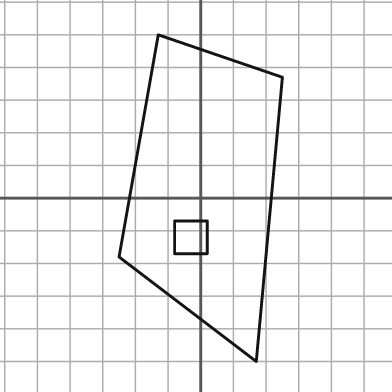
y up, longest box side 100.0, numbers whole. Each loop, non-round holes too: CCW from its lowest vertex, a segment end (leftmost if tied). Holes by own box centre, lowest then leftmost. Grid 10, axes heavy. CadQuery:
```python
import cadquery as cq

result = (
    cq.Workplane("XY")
    .moveTo(17.0, -50.0)
    .lineTo(25.0, 37.0)
    .lineTo(-13.0, 50.0)
    .lineTo(-25.0, -18.0)
    .close()
    .moveTo(-8.0, -17.0)
    .lineTo(2.0, -17.0)
    .lineTo(2.0, -7.0)
    .lineTo(-8.0, -7.0)
    .close()
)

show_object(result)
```